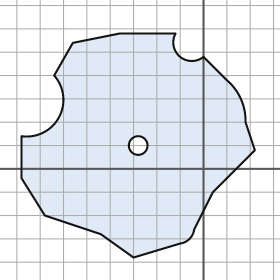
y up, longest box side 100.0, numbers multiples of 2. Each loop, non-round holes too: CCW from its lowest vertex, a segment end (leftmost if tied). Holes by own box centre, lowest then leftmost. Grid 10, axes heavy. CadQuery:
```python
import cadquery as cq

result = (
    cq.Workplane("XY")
    .moveTo(-30.0, -38.0)
    .lineTo(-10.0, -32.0)
    .threePointArc((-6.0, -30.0), (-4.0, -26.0))
    .lineTo(4.0, -10.0)
    .lineTo(22.0, 8.0)
    .lineTo(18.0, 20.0)
    .threePointArc((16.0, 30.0), (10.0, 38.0))
    .lineTo(0.0, 48.0)
    .threePointArc((-10.0, 48.0), (-12.0, 58.0))
    .lineTo(-36.0, 58.0)
    .lineTo(-56.0, 54.0)
    .lineTo(-64.0, 40.0)
    .threePointArc((-62.0, 22.0), (-78.0, 14.0))
    .lineTo(-78.0, -4.0)
    .lineTo(-68.0, -20.0)
    .lineTo(-44.0, -28.0)
    .close()
    .moveTo(-28.0, 10.0)
    .circle(4.0)
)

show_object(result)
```